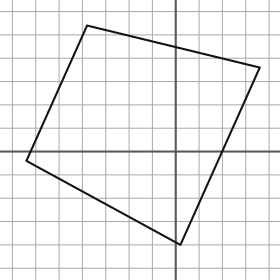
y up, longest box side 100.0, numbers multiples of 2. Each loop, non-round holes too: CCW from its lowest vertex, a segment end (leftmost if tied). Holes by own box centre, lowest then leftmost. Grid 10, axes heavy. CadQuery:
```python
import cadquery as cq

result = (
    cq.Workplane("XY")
    .moveTo(2.0, -40.0)
    .lineTo(36.0, 36.0)
    .lineTo(-38.0, 54.0)
    .lineTo(-64.0, -4.0)
    .close()
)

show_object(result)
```